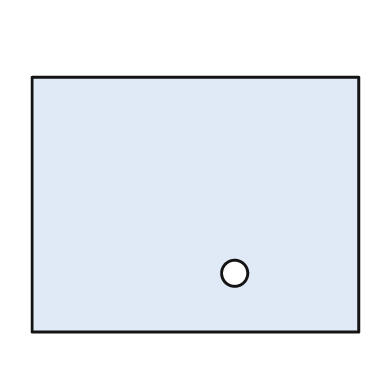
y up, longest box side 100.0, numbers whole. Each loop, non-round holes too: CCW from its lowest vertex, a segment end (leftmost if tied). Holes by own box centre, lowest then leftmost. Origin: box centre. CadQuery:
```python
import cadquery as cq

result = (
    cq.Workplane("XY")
    .moveTo(-50.0, -39.0)
    .lineTo(50.0, -39.0)
    .lineTo(50.0, 39.0)
    .lineTo(-50.0, 39.0)
    .close()
    .moveTo(12.0, -21.0)
    .circle(4.0)
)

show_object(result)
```